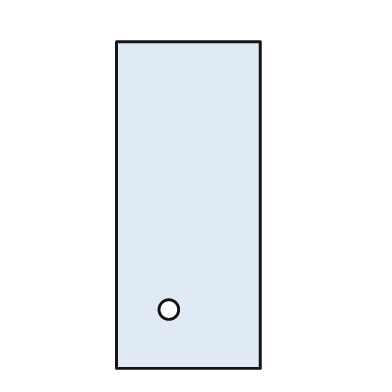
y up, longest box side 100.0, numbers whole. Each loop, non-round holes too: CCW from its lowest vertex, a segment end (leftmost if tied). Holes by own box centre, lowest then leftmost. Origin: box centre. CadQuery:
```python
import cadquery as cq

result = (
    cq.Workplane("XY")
    .moveTo(-22.0, -50.0)
    .lineTo(22.0, -50.0)
    .lineTo(22.0, 50.0)
    .lineTo(-22.0, 50.0)
    .close()
    .moveTo(-6.0, -32.0)
    .circle(3.0)
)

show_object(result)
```